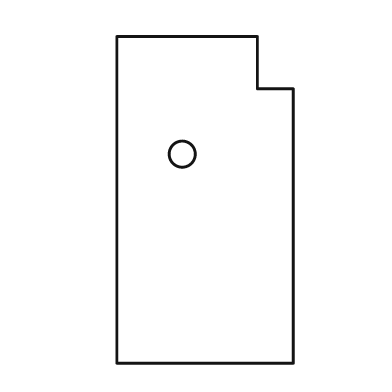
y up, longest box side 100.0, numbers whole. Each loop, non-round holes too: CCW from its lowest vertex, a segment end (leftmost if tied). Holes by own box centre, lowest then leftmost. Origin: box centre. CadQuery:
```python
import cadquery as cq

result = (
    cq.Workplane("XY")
    .moveTo(-27.0, -50.0)
    .lineTo(27.0, -50.0)
    .lineTo(27.0, 34.0)
    .lineTo(16.0, 34.0)
    .lineTo(16.0, 50.0)
    .lineTo(-27.0, 50.0)
    .close()
    .moveTo(-7.0, 14.0)
    .circle(4.0)
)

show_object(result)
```